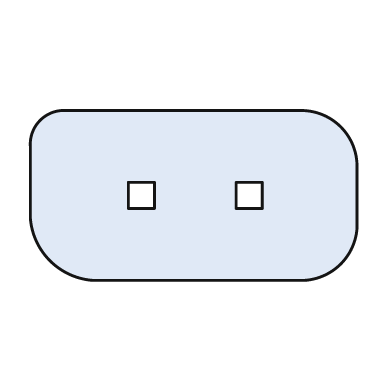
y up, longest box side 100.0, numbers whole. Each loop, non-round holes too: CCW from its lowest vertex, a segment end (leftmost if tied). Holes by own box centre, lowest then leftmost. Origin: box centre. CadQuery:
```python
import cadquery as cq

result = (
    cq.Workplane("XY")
    .moveTo(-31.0, -26.0)
    .lineTo(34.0, -26.0)
    .threePointArc((45.0, -21.0), (50.0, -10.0))
    .lineTo(50.0, 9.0)
    .threePointArc((45.0, 21.0), (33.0, 26.0))
    .lineTo(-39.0, 26.0)
    .threePointArc((-47.0, 23.0), (-50.0, 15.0))
    .lineTo(-50.0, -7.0)
    .threePointArc((-44.0, -20.0), (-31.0, -26.0))
    .close()
    .moveTo(-20.0, -4.0)
    .lineTo(-12.0, -4.0)
    .lineTo(-12.0, 4.0)
    .lineTo(-20.0, 4.0)
    .close()
    .moveTo(13.0, -4.0)
    .lineTo(21.0, -4.0)
    .lineTo(21.0, 4.0)
    .lineTo(13.0, 4.0)
    .close()
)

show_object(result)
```